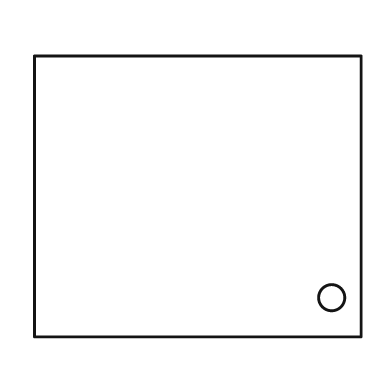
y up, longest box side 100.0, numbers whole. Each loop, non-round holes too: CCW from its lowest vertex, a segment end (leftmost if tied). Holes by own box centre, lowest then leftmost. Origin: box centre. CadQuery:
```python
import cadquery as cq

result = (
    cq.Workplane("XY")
    .moveTo(-50.0, -43.0)
    .lineTo(50.0, -43.0)
    .lineTo(50.0, 43.0)
    .lineTo(-50.0, 43.0)
    .close()
    .moveTo(41.0, -31.0)
    .circle(4.0)
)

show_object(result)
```